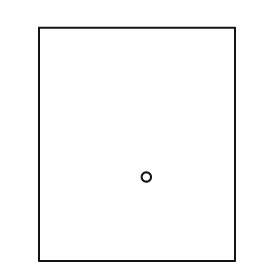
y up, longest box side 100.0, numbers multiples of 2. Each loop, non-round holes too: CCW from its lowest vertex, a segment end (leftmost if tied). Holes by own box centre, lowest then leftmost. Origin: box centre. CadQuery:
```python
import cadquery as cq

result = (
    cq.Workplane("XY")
    .moveTo(-42.0, -50.0)
    .lineTo(42.0, -50.0)
    .lineTo(42.0, 50.0)
    .lineTo(-42.0, 50.0)
    .close()
    .moveTo(4.0, -14.0)
    .circle(2.0)
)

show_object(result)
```